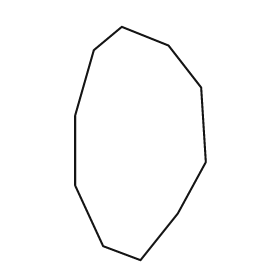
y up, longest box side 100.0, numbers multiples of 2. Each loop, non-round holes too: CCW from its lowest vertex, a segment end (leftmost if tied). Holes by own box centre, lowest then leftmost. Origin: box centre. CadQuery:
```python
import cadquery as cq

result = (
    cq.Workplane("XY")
    .moveTo(0.0, -50.0)
    .lineTo(16.0, -30.0)
    .lineTo(28.0, -8.0)
    .lineTo(26.0, 24.0)
    .lineTo(12.0, 42.0)
    .lineTo(-8.0, 50.0)
    .lineTo(-20.0, 40.0)
    .lineTo(-28.0, 12.0)
    .lineTo(-28.0, -18.0)
    .lineTo(-16.0, -44.0)
    .close()
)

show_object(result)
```